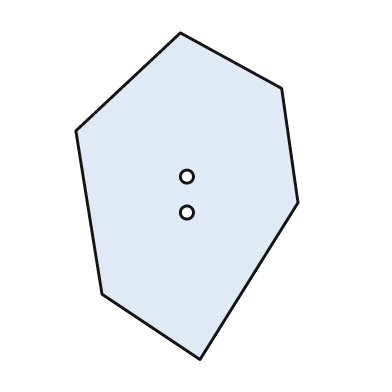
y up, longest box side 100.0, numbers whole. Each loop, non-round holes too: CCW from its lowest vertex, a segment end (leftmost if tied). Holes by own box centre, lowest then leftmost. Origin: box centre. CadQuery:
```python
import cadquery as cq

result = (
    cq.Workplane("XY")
    .moveTo(4.0, -50.0)
    .lineTo(34.0, -2.0)
    .lineTo(29.0, 33.0)
    .lineTo(-2.0, 50.0)
    .lineTo(-34.0, 20.0)
    .lineTo(-26.0, -30.0)
    .close()
    .moveTo(0.0, -5.0)
    .circle(2.0)
    .moveTo(0.0, 6.0)
    .circle(2.0)
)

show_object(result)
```